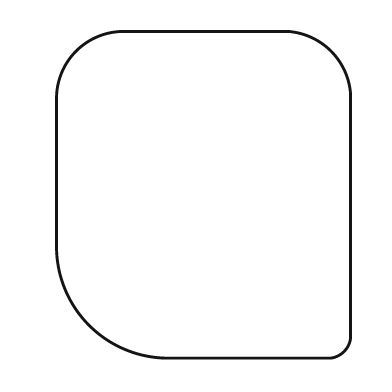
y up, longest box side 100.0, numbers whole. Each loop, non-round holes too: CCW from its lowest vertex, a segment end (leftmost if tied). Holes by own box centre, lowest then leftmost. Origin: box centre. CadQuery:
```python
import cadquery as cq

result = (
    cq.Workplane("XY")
    .moveTo(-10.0, -50.0)
    .lineTo(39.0, -50.0)
    .threePointArc((43.0, -48.0), (45.0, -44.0))
    .lineTo(45.0, 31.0)
    .threePointArc((39.0, 44.0), (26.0, 50.0))
    .lineTo(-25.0, 50.0)
    .threePointArc((-39.0, 44.0), (-45.0, 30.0))
    .lineTo(-45.0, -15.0)
    .threePointArc((-35.0, -40.0), (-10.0, -50.0))
    .close()
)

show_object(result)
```